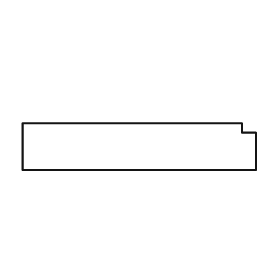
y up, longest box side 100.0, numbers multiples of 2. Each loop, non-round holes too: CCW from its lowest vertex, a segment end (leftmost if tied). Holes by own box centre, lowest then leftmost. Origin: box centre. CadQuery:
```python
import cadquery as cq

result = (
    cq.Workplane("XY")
    .moveTo(-50.0, -10.0)
    .lineTo(50.0, -10.0)
    .lineTo(50.0, 6.0)
    .lineTo(44.0, 6.0)
    .lineTo(44.0, 10.0)
    .lineTo(-50.0, 10.0)
    .close()
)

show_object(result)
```